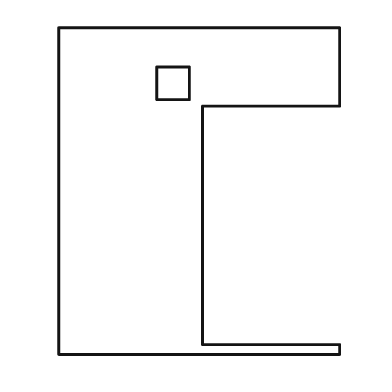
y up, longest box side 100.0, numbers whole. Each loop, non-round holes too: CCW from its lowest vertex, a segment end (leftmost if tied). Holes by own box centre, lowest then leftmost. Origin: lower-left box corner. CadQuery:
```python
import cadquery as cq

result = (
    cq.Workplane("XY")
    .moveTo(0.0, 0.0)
    .lineTo(86.0, 0.0)
    .lineTo(86.0, 3.0)
    .lineTo(44.0, 3.0)
    .lineTo(44.0, 76.0)
    .lineTo(86.0, 76.0)
    .lineTo(86.0, 100.0)
    .lineTo(0.0, 100.0)
    .close()
    .moveTo(30.0, 78.0)
    .lineTo(40.0, 78.0)
    .lineTo(40.0, 88.0)
    .lineTo(30.0, 88.0)
    .close()
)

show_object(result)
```